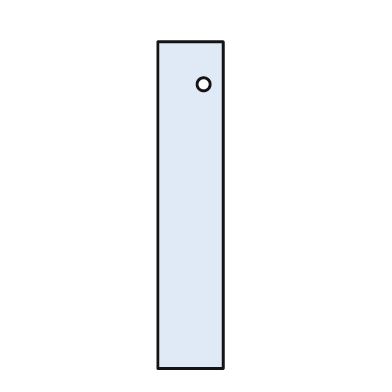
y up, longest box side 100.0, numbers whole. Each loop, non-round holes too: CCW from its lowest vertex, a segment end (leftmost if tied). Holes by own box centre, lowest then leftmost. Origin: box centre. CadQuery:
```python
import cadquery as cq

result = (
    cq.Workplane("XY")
    .moveTo(-10.0, -50.0)
    .lineTo(10.0, -50.0)
    .lineTo(10.0, 50.0)
    .lineTo(-10.0, 50.0)
    .close()
    .moveTo(4.0, 37.0)
    .circle(2.0)
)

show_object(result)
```